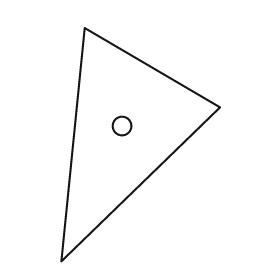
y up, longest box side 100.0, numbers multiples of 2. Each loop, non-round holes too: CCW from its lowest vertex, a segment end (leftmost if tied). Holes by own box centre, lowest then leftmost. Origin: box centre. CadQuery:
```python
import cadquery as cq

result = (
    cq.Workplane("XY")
    .moveTo(-34.0, -50.0)
    .lineTo(34.0, 16.0)
    .lineTo(-24.0, 50.0)
    .close()
    .moveTo(-8.0, 8.0)
    .circle(4.0)
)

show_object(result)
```